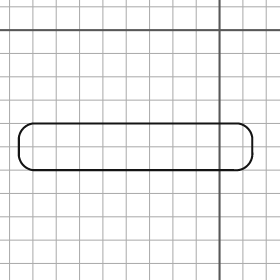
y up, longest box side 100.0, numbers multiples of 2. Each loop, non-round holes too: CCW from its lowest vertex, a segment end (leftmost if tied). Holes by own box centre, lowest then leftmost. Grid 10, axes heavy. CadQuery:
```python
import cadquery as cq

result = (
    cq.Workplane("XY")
    .moveTo(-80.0, -60.0)
    .lineTo(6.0, -60.0)
    .threePointArc((12.0, -58.0), (14.0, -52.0))
    .lineTo(14.0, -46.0)
    .threePointArc((12.0, -42.0), (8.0, -40.0))
    .lineTo(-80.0, -40.0)
    .threePointArc((-84.0, -42.0), (-86.0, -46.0))
    .lineTo(-86.0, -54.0)
    .threePointArc((-84.0, -58.0), (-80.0, -60.0))
    .close()
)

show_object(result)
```